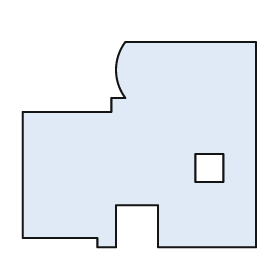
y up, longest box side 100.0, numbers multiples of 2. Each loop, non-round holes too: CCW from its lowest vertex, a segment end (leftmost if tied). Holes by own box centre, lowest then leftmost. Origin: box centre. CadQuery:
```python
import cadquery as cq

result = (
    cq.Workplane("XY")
    .moveTo(-18.0, -44.0)
    .lineTo(-10.0, -44.0)
    .lineTo(-10.0, -26.0)
    .lineTo(8.0, -26.0)
    .lineTo(8.0, -44.0)
    .lineTo(50.0, -44.0)
    .lineTo(50.0, 44.0)
    .lineTo(-6.0, 44.0)
    .threePointArc((-10.0, 32.0), (-6.0, 20.0))
    .lineTo(-12.0, 20.0)
    .lineTo(-12.0, 14.0)
    .lineTo(-50.0, 14.0)
    .lineTo(-50.0, -40.0)
    .lineTo(-18.0, -40.0)
    .close()
    .moveTo(24.0, -16.0)
    .lineTo(36.0, -16.0)
    .lineTo(36.0, -4.0)
    .lineTo(24.0, -4.0)
    .close()
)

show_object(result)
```